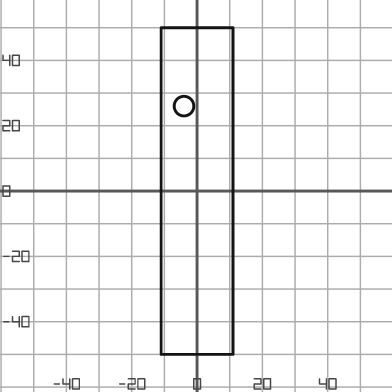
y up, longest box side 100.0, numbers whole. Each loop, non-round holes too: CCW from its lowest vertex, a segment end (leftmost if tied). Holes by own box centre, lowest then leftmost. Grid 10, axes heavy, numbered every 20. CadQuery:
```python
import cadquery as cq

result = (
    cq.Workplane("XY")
    .moveTo(-11.0, -50.0)
    .lineTo(11.0, -50.0)
    .lineTo(11.0, 50.0)
    .lineTo(-11.0, 50.0)
    .close()
    .moveTo(-4.0, 26.0)
    .circle(3.0)
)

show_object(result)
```